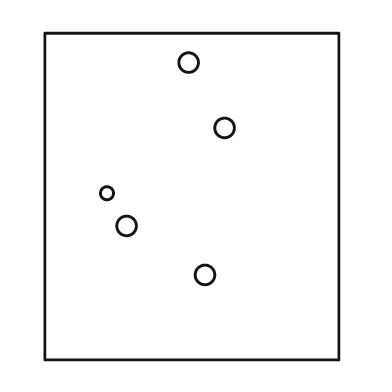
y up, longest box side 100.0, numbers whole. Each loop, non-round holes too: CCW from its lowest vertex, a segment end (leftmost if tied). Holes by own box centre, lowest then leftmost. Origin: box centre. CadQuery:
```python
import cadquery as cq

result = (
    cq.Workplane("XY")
    .moveTo(-45.0, -50.0)
    .lineTo(45.0, -50.0)
    .lineTo(45.0, 50.0)
    .lineTo(-45.0, 50.0)
    .close()
    .moveTo(4.0, -24.0)
    .circle(3.0)
    .moveTo(-20.0, -9.0)
    .circle(3.0)
    .moveTo(-26.0, 1.0)
    .circle(2.0)
    .moveTo(10.0, 21.0)
    .circle(3.0)
    .moveTo(-1.0, 41.0)
    .circle(3.0)
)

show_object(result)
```